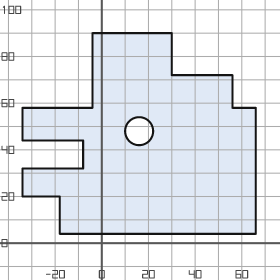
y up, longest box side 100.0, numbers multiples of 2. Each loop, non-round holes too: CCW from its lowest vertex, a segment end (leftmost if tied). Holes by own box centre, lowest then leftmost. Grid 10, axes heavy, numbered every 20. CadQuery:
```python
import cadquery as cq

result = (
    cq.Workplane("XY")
    .moveTo(-18.0, 4.0)
    .lineTo(66.0, 4.0)
    .lineTo(66.0, 58.0)
    .lineTo(56.0, 58.0)
    .lineTo(56.0, 72.0)
    .lineTo(30.0, 72.0)
    .lineTo(30.0, 90.0)
    .lineTo(-4.0, 90.0)
    .lineTo(-4.0, 58.0)
    .lineTo(-34.0, 58.0)
    .lineTo(-34.0, 44.0)
    .lineTo(-8.0, 44.0)
    .lineTo(-8.0, 32.0)
    .lineTo(-34.0, 32.0)
    .lineTo(-34.0, 20.0)
    .lineTo(-18.0, 20.0)
    .close()
    .moveTo(16.0, 48.0)
    .circle(6.0)
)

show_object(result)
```